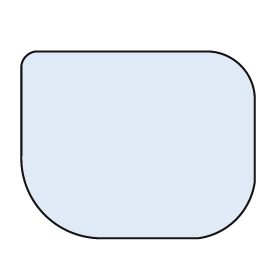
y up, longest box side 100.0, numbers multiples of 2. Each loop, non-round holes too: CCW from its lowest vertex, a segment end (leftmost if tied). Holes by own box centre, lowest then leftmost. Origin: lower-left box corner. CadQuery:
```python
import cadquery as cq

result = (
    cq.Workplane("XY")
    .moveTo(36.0, 0.0)
    .lineTo(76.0, 0.0)
    .threePointArc((92.0, 8.0), (100.0, 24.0))
    .lineTo(100.0, 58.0)
    .threePointArc((94.0, 74.0), (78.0, 80.0))
    .lineTo(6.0, 80.0)
    .threePointArc((2.0, 78.0), (0.0, 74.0))
    .lineTo(0.0, 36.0)
    .threePointArc((10.0, 10.0), (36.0, 0.0))
    .close()
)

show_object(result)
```